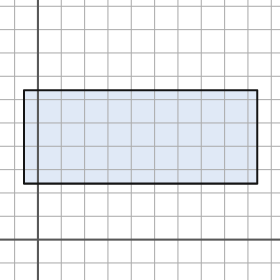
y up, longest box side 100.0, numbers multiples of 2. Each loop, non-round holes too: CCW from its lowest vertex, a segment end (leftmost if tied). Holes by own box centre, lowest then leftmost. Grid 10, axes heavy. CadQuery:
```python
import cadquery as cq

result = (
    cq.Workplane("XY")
    .moveTo(-6.0, 24.0)
    .lineTo(94.0, 24.0)
    .lineTo(94.0, 64.0)
    .lineTo(-6.0, 64.0)
    .close()
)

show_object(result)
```